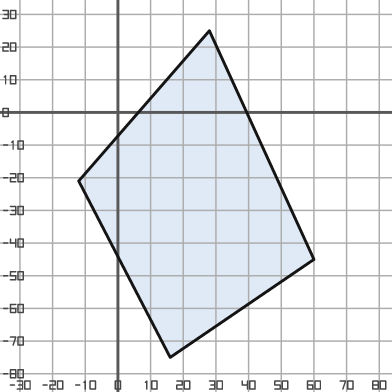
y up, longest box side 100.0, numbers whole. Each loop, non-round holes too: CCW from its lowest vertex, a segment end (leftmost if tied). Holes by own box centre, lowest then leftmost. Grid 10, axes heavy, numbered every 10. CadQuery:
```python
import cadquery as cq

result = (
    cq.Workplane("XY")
    .moveTo(16.0, -75.0)
    .lineTo(60.0, -45.0)
    .lineTo(28.0, 25.0)
    .lineTo(-12.0, -21.0)
    .close()
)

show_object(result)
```